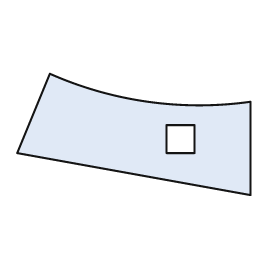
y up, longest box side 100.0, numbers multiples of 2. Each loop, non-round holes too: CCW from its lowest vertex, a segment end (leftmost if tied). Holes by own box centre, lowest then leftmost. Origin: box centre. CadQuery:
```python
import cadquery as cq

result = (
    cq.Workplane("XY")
    .moveTo(50.0, -26.0)
    .lineTo(50.0, 14.0)
    .threePointArc((6.0, 14.0), (-36.0, 26.0))
    .lineTo(-50.0, -8.0)
    .close()
    .moveTo(14.0, -8.0)
    .lineTo(26.0, -8.0)
    .lineTo(26.0, 4.0)
    .lineTo(14.0, 4.0)
    .close()
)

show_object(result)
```